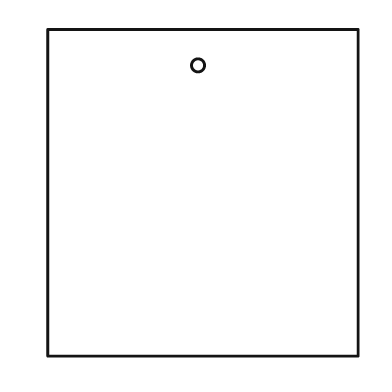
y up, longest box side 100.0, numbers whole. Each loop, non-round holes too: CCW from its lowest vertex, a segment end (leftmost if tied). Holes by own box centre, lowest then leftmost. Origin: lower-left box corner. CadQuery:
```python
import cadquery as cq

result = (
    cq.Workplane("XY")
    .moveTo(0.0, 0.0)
    .lineTo(95.0, 0.0)
    .lineTo(95.0, 100.0)
    .lineTo(0.0, 100.0)
    .close()
    .moveTo(46.0, 89.0)
    .circle(2.0)
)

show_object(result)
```